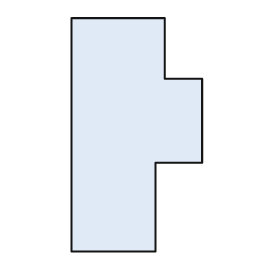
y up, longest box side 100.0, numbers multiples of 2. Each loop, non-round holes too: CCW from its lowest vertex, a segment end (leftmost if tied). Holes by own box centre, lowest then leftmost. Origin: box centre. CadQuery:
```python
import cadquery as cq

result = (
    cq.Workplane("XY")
    .moveTo(-28.0, -50.0)
    .lineTo(8.0, -50.0)
    .lineTo(8.0, -12.0)
    .lineTo(28.0, -12.0)
    .lineTo(28.0, 24.0)
    .lineTo(12.0, 24.0)
    .lineTo(12.0, 50.0)
    .lineTo(-28.0, 50.0)
    .close()
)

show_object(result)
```